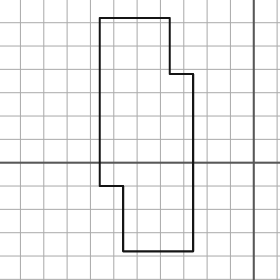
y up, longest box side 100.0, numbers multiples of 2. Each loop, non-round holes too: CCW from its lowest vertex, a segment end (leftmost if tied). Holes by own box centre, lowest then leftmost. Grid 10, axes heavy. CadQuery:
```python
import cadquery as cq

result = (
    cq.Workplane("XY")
    .moveTo(-56.0, -38.0)
    .lineTo(-26.0, -38.0)
    .lineTo(-26.0, 38.0)
    .lineTo(-36.0, 38.0)
    .lineTo(-36.0, 62.0)
    .lineTo(-66.0, 62.0)
    .lineTo(-66.0, -10.0)
    .lineTo(-56.0, -10.0)
    .close()
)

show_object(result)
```